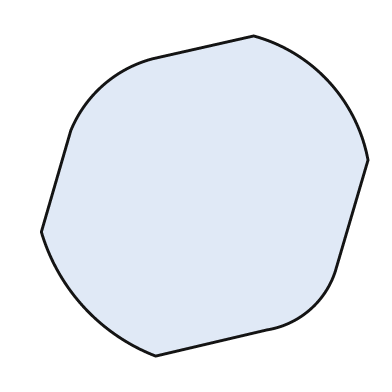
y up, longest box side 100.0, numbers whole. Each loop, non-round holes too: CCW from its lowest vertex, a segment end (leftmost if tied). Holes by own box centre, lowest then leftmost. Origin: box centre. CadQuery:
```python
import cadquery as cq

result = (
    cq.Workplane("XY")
    .moveTo(-15.0, -49.0)
    .lineTo(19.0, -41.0)
    .threePointArc((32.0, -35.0), (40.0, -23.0))
    .lineTo(50.0, 11.0)
    .threePointArc((38.0, 35.0), (15.0, 49.0))
    .lineTo(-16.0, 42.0)
    .threePointArc((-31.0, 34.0), (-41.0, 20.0))
    .lineTo(-50.0, -11.0)
    .threePointArc((-37.0, -34.0), (-15.0, -49.0))
    .close()
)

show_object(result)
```